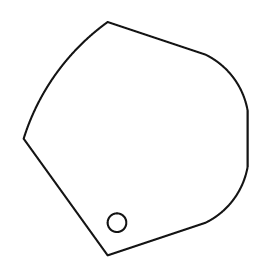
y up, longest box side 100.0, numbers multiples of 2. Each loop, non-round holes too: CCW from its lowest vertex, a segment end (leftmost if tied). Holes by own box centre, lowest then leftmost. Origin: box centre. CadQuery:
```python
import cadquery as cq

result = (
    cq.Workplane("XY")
    .moveTo(-12.0, -50.0)
    .lineTo(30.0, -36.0)
    .threePointArc((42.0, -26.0), (48.0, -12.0))
    .lineTo(48.0, 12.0)
    .threePointArc((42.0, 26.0), (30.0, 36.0))
    .lineTo(-12.0, 50.0)
    .threePointArc((-34.0, 28.0), (-48.0, 0.0))
    .close()
    .moveTo(-8.0, -36.0)
    .circle(4.0)
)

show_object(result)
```